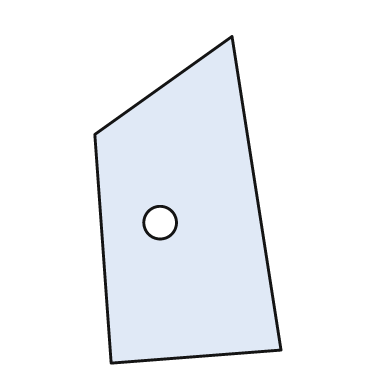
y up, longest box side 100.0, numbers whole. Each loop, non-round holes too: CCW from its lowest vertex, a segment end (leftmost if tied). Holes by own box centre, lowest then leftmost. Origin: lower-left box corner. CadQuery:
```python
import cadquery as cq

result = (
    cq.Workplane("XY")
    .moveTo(5.0, 0.0)
    .lineTo(57.0, 4.0)
    .lineTo(42.0, 100.0)
    .lineTo(0.0, 70.0)
    .close()
    .moveTo(20.0, 43.0)
    .circle(5.0)
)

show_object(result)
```